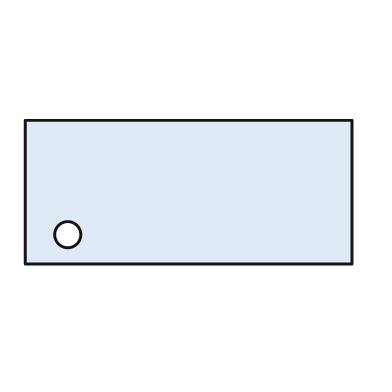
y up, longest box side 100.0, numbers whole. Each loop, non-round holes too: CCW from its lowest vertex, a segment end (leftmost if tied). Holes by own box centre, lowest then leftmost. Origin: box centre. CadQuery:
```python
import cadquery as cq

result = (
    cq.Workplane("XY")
    .moveTo(-50.0, -22.0)
    .lineTo(50.0, -22.0)
    .lineTo(50.0, 22.0)
    .lineTo(-50.0, 22.0)
    .close()
    .moveTo(-37.0, -13.0)
    .circle(4.0)
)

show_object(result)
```